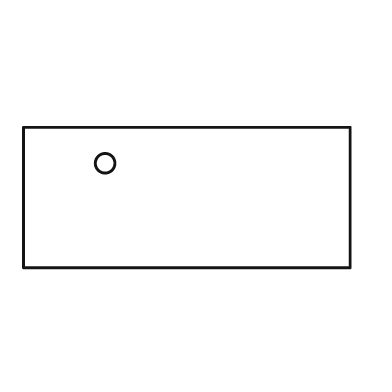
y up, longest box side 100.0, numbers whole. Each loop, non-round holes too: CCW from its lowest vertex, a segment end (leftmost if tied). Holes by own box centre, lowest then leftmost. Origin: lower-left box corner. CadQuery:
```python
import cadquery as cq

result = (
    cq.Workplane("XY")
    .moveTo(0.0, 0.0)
    .lineTo(100.0, 0.0)
    .lineTo(100.0, 43.0)
    .lineTo(0.0, 43.0)
    .close()
    .moveTo(25.0, 32.0)
    .circle(3.0)
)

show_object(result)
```